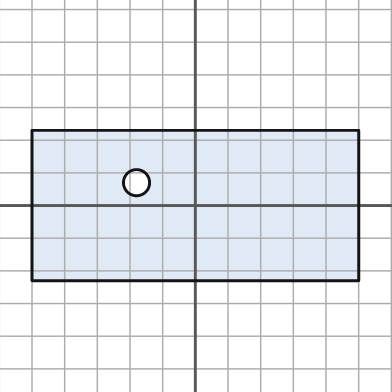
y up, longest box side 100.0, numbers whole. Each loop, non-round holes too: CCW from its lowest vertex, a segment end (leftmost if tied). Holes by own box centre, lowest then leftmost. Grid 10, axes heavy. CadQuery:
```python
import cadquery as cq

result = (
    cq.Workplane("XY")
    .moveTo(-50.0, -23.0)
    .lineTo(50.0, -23.0)
    .lineTo(50.0, 23.0)
    .lineTo(-50.0, 23.0)
    .close()
    .moveTo(-18.0, 7.0)
    .circle(4.0)
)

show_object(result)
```